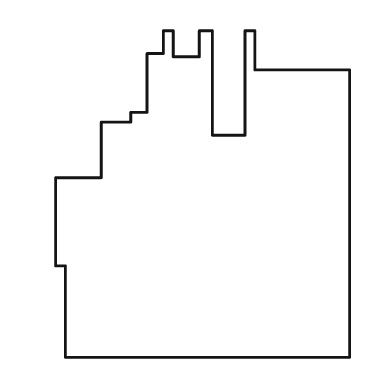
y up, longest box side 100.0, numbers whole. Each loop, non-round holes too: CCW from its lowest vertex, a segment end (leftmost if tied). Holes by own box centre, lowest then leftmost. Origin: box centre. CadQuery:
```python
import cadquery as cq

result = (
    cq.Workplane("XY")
    .moveTo(-42.0, -50.0)
    .lineTo(45.0, -50.0)
    .lineTo(45.0, 38.0)
    .lineTo(16.0, 38.0)
    .lineTo(16.0, 50.0)
    .lineTo(13.0, 50.0)
    .lineTo(13.0, 18.0)
    .lineTo(3.0, 18.0)
    .lineTo(3.0, 50.0)
    .lineTo(-1.0, 50.0)
    .lineTo(-1.0, 42.0)
    .lineTo(-9.0, 42.0)
    .lineTo(-9.0, 50.0)
    .lineTo(-12.0, 50.0)
    .lineTo(-12.0, 43.0)
    .lineTo(-17.0, 43.0)
    .lineTo(-17.0, 25.0)
    .lineTo(-22.0, 25.0)
    .lineTo(-22.0, 22.0)
    .lineTo(-31.0, 22.0)
    .lineTo(-31.0, 5.0)
    .lineTo(-45.0, 5.0)
    .lineTo(-45.0, -22.0)
    .lineTo(-42.0, -22.0)
    .close()
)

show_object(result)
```